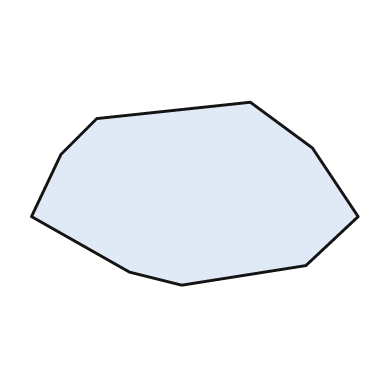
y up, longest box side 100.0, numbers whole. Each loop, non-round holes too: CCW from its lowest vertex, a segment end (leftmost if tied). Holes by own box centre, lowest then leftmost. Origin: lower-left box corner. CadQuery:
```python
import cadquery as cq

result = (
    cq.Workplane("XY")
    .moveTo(46.0, 0.0)
    .lineTo(84.0, 6.0)
    .lineTo(100.0, 21.0)
    .lineTo(86.0, 42.0)
    .lineTo(67.0, 56.0)
    .lineTo(20.0, 51.0)
    .lineTo(9.0, 40.0)
    .lineTo(0.0, 21.0)
    .lineTo(30.0, 4.0)
    .close()
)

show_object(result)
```